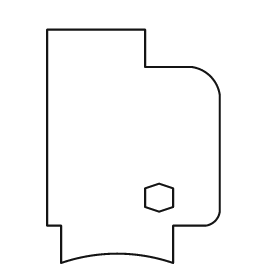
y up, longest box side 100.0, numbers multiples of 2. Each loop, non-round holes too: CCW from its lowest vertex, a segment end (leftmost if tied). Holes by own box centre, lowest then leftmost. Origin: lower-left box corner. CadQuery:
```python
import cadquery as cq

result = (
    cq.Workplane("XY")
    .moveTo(6.0, 0.0)
    .threePointArc((30.0, 4.0), (54.0, 0.0))
    .lineTo(54.0, 16.0)
    .lineTo(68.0, 16.0)
    .threePointArc((72.0, 18.0), (74.0, 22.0))
    .lineTo(74.0, 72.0)
    .threePointArc((70.0, 80.0), (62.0, 84.0))
    .lineTo(42.0, 84.0)
    .lineTo(42.0, 100.0)
    .lineTo(0.0, 100.0)
    .lineTo(0.0, 16.0)
    .lineTo(6.0, 16.0)
    .close()
    .moveTo(48.0, 22.0)
    .lineTo(54.0, 24.0)
    .lineTo(54.0, 32.0)
    .lineTo(48.0, 34.0)
    .lineTo(42.0, 32.0)
    .lineTo(42.0, 24.0)
    .close()
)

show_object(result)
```